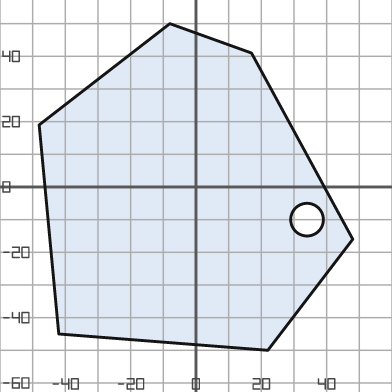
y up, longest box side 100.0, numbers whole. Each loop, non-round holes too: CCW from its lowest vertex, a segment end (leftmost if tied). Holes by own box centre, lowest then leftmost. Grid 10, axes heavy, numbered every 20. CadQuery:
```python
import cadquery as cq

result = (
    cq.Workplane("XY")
    .moveTo(22.0, -50.0)
    .lineTo(48.0, -16.0)
    .lineTo(17.0, 41.0)
    .lineTo(-8.0, 50.0)
    .lineTo(-48.0, 19.0)
    .lineTo(-42.0, -45.0)
    .close()
    .moveTo(34.0, -10.0)
    .circle(5.0)
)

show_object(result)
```